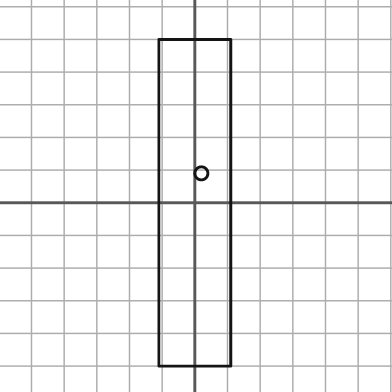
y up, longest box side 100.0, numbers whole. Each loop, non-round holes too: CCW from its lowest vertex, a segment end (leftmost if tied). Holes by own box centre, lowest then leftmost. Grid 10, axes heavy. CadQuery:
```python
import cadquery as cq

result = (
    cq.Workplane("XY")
    .moveTo(-11.0, -50.0)
    .lineTo(11.0, -50.0)
    .lineTo(11.0, 50.0)
    .lineTo(-11.0, 50.0)
    .close()
    .moveTo(2.0, 9.0)
    .circle(2.0)
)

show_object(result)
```